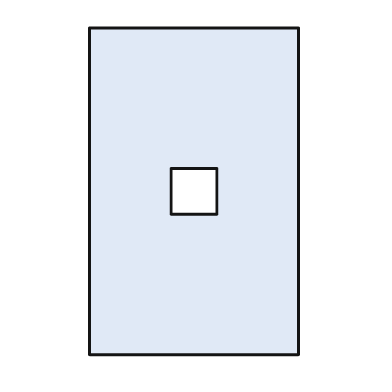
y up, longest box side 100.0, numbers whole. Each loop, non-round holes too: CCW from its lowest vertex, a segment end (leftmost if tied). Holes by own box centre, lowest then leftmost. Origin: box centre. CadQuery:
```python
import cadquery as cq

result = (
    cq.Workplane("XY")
    .moveTo(-32.0, -50.0)
    .lineTo(32.0, -50.0)
    .lineTo(32.0, 50.0)
    .lineTo(-32.0, 50.0)
    .close()
    .moveTo(-7.0, -7.0)
    .lineTo(7.0, -7.0)
    .lineTo(7.0, 7.0)
    .lineTo(-7.0, 7.0)
    .close()
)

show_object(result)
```